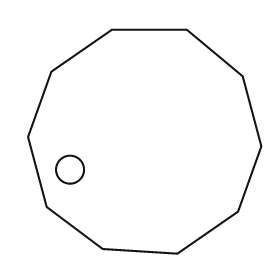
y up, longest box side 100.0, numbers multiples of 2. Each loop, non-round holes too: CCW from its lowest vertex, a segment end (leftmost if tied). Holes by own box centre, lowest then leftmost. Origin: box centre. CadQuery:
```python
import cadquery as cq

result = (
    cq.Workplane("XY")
    .moveTo(14.0, -48.0)
    .lineTo(40.0, -30.0)
    .lineTo(50.0, -2.0)
    .lineTo(42.0, 28.0)
    .lineTo(18.0, 48.0)
    .lineTo(-14.0, 48.0)
    .lineTo(-40.0, 30.0)
    .lineTo(-50.0, 2.0)
    .lineTo(-42.0, -28.0)
    .lineTo(-18.0, -46.0)
    .close()
    .moveTo(-32.0, -12.0)
    .circle(6.0)
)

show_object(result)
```